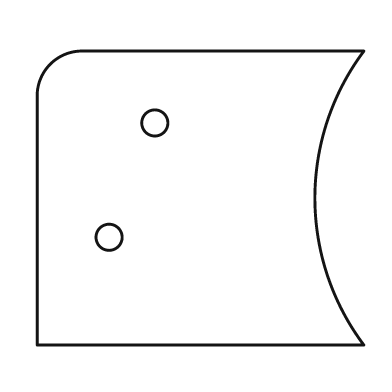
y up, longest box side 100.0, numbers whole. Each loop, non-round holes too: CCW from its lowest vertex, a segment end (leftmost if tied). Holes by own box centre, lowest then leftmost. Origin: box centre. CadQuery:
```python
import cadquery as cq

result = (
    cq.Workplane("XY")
    .moveTo(-50.0, -45.0)
    .lineTo(50.0, -45.0)
    .threePointArc((35.0, 0.0), (50.0, 45.0))
    .lineTo(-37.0, 45.0)
    .threePointArc((-46.0, 41.0), (-50.0, 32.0))
    .close()
    .moveTo(-28.0, -12.0)
    .circle(4.0)
    .moveTo(-14.0, 23.0)
    .circle(4.0)
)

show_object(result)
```